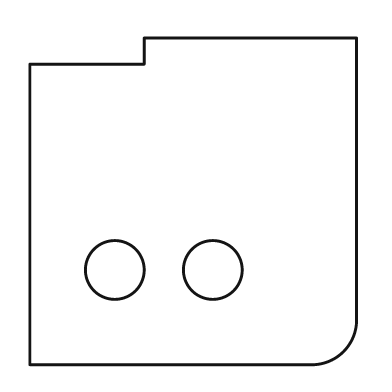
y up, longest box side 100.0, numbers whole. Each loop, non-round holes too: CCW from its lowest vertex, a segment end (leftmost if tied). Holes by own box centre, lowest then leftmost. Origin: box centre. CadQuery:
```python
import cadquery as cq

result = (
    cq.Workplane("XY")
    .moveTo(-50.0, -50.0)
    .lineTo(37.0, -50.0)
    .threePointArc((46.0, -46.0), (50.0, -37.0))
    .lineTo(50.0, 50.0)
    .lineTo(-15.0, 50.0)
    .lineTo(-15.0, 42.0)
    .lineTo(-50.0, 42.0)
    .close()
    .moveTo(-24.0, -21.0)
    .circle(9.0)
    .moveTo(6.0, -21.0)
    .circle(9.0)
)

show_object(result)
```